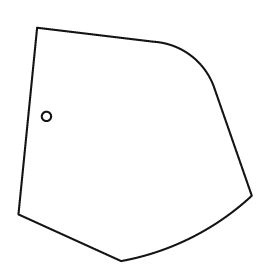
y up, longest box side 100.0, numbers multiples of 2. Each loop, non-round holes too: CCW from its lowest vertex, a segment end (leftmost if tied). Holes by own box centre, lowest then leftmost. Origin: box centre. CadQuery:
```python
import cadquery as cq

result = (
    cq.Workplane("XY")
    .moveTo(-6.0, -50.0)
    .threePointArc((24.0, -40.0), (50.0, -22.0))
    .lineTo(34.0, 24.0)
    .threePointArc((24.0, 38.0), (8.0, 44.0))
    .lineTo(-42.0, 50.0)
    .lineTo(-50.0, -30.0)
    .close()
    .moveTo(-38.0, 12.0)
    .circle(2.0)
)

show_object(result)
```